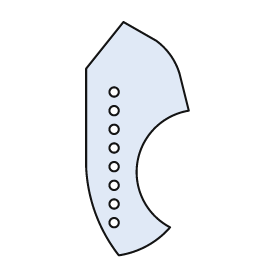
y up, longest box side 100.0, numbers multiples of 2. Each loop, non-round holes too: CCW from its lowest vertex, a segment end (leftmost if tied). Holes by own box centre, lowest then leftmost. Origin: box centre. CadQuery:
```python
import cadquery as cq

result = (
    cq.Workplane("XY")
    .moveTo(-8.0, -50.0)
    .threePointArc((4.0, -46.0), (14.0, -38.0))
    .threePointArc((0.0, -10.0), (22.0, 12.0))
    .lineTo(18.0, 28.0)
    .threePointArc((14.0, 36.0), (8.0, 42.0))
    .lineTo(-6.0, 50.0)
    .lineTo(-22.0, 30.0)
    .lineTo(-22.0, -12.0)
    .threePointArc((-18.0, -32.0), (-8.0, -50.0))
    .close()
    .moveTo(-10.0, -36.0)
    .circle(2.0)
    .moveTo(-10.0, -28.0)
    .circle(2.0)
    .moveTo(-10.0, -20.0)
    .circle(2.0)
    .moveTo(-10.0, -12.0)
    .circle(2.0)
    .moveTo(-10.0, -4.0)
    .circle(2.0)
    .moveTo(-10.0, 4.0)
    .circle(2.0)
    .moveTo(-10.0, 12.0)
    .circle(2.0)
    .moveTo(-10.0, 20.0)
    .circle(2.0)
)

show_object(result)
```